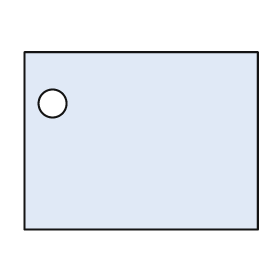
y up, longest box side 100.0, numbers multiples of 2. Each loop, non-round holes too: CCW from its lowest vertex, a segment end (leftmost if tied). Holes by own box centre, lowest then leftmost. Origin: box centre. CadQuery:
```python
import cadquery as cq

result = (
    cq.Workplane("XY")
    .moveTo(-50.0, -38.0)
    .lineTo(50.0, -38.0)
    .lineTo(50.0, 38.0)
    .lineTo(-50.0, 38.0)
    .close()
    .moveTo(-38.0, 16.0)
    .circle(6.0)
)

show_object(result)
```